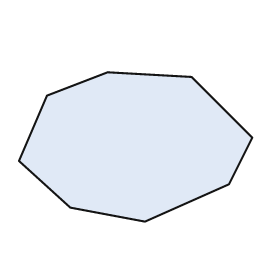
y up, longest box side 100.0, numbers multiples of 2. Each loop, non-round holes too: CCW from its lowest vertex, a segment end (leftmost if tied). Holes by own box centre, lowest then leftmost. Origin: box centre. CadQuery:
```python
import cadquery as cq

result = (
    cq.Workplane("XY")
    .moveTo(4.0, -32.0)
    .lineTo(40.0, -16.0)
    .lineTo(50.0, 4.0)
    .lineTo(24.0, 30.0)
    .lineTo(-12.0, 32.0)
    .lineTo(-38.0, 22.0)
    .lineTo(-50.0, -6.0)
    .lineTo(-28.0, -26.0)
    .close()
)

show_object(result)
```